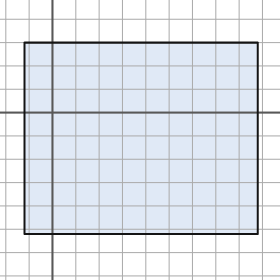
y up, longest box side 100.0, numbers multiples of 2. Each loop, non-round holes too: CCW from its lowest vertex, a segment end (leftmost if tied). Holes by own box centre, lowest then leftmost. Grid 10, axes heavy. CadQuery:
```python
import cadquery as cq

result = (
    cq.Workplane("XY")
    .moveTo(-12.0, -52.0)
    .lineTo(88.0, -52.0)
    .lineTo(88.0, 30.0)
    .lineTo(-12.0, 30.0)
    .close()
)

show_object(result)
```